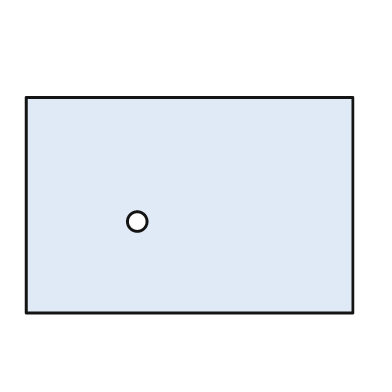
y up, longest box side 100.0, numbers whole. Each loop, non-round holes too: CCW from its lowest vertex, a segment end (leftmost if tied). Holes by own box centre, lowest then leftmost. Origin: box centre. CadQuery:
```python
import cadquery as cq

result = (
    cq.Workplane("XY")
    .moveTo(-50.0, -33.0)
    .lineTo(50.0, -33.0)
    .lineTo(50.0, 33.0)
    .lineTo(-50.0, 33.0)
    .close()
    .moveTo(-16.0, -5.0)
    .circle(3.0)
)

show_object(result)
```